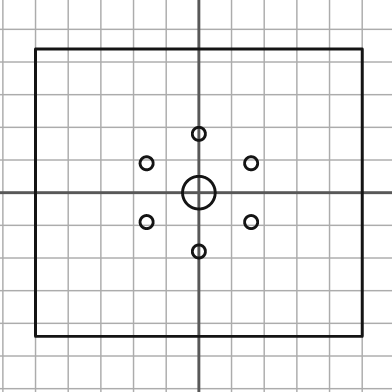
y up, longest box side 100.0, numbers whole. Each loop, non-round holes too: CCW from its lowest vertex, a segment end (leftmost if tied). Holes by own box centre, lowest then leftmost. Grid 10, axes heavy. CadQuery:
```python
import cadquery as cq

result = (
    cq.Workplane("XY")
    .moveTo(-50.0, -44.0)
    .lineTo(50.0, -44.0)
    .lineTo(50.0, 44.0)
    .lineTo(-50.0, 44.0)
    .close()
    .moveTo(0.0, -18.0)
    .circle(2.0)
    .moveTo(-16.0, -9.0)
    .circle(2.0)
    .moveTo(16.0, -9.0)
    .circle(2.0)
    .moveTo(0.0, 0.0)
    .circle(5.0)
    .moveTo(-16.0, 9.0)
    .circle(2.0)
    .moveTo(16.0, 9.0)
    .circle(2.0)
    .moveTo(0.0, 18.0)
    .circle(2.0)
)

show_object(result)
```